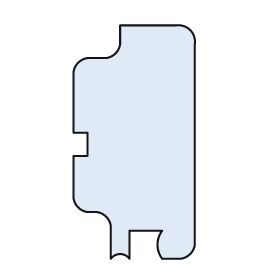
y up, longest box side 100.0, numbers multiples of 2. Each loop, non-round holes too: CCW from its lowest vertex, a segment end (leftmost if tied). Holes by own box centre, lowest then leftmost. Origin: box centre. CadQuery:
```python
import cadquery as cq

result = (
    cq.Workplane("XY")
    .moveTo(-10.0, -50.0)
    .threePointArc((-6.0, -48.0), (-2.0, -50.0))
    .lineTo(-2.0, -38.0)
    .lineTo(12.0, -38.0)
    .threePointArc((10.0, -44.0), (12.0, -50.0))
    .lineTo(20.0, -50.0)
    .threePointArc((24.0, -48.0), (26.0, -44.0))
    .lineTo(26.0, 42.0)
    .threePointArc((24.0, 48.0), (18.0, 50.0))
    .lineTo(-6.0, 50.0)
    .lineTo(-6.0, 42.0)
    .threePointArc((-8.0, 38.0), (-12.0, 36.0))
    .lineTo(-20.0, 36.0)
    .threePointArc((-24.0, 34.0), (-26.0, 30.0))
    .lineTo(-26.0, 4.0)
    .lineTo(-20.0, 4.0)
    .lineTo(-20.0, -6.0)
    .lineTo(-26.0, -6.0)
    .lineTo(-26.0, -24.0)
    .threePointArc((-24.0, -28.0), (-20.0, -30.0))
    .lineTo(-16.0, -30.0)
    .threePointArc((-12.0, -32.0), (-10.0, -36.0))
    .close()
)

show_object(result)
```